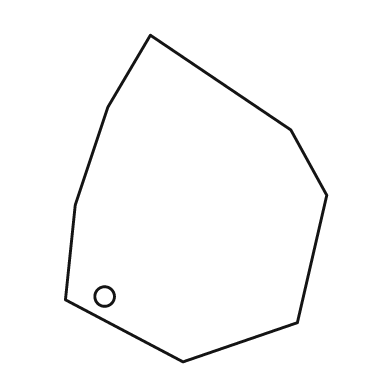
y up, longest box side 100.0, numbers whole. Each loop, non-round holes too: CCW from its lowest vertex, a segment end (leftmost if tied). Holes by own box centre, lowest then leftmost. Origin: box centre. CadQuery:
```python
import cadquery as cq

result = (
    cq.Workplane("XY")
    .moveTo(-4.0, -50.0)
    .lineTo(31.0, -38.0)
    .lineTo(40.0, 1.0)
    .lineTo(29.0, 21.0)
    .lineTo(-14.0, 50.0)
    .lineTo(-27.0, 28.0)
    .lineTo(-37.0, -2.0)
    .lineTo(-40.0, -31.0)
    .close()
    .moveTo(-28.0, -30.0)
    .circle(3.0)
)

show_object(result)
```